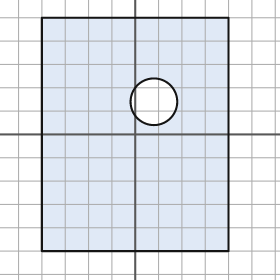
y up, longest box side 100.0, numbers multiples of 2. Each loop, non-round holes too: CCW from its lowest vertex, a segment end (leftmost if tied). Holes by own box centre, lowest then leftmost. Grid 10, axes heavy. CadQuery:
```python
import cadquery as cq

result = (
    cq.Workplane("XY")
    .moveTo(-40.0, -50.0)
    .lineTo(40.0, -50.0)
    .lineTo(40.0, 50.0)
    .lineTo(-40.0, 50.0)
    .close()
    .moveTo(8.0, 14.0)
    .circle(10.0)
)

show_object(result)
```